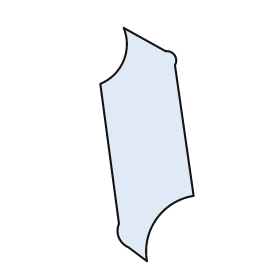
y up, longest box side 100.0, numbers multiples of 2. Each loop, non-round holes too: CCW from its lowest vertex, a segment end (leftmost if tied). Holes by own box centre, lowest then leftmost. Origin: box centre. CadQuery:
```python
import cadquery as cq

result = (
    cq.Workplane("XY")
    .moveTo(0.0, -50.0)
    .threePointArc((4.0, -32.0), (20.0, -22.0))
    .lineTo(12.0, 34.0)
    .threePointArc((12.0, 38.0), (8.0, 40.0))
    .lineTo(-10.0, 50.0)
    .threePointArc((-10.0, 36.0), (-20.0, 26.0))
    .lineTo(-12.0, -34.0)
    .threePointArc((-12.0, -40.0), (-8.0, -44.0))
    .close()
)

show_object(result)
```